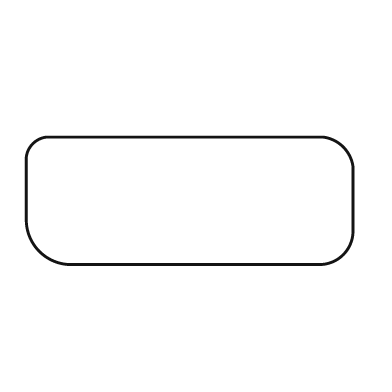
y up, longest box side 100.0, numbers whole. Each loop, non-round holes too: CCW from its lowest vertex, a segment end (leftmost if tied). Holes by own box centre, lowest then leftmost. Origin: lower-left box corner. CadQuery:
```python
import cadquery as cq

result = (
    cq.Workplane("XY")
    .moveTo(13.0, 0.0)
    .lineTo(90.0, 0.0)
    .threePointArc((97.0, 3.0), (100.0, 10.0))
    .lineTo(100.0, 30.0)
    .threePointArc((97.0, 36.0), (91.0, 39.0))
    .lineTo(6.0, 39.0)
    .threePointArc((2.0, 37.0), (0.0, 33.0))
    .lineTo(0.0, 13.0)
    .threePointArc((4.0, 4.0), (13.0, 0.0))
    .close()
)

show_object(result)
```